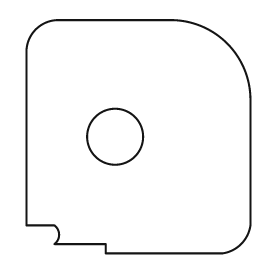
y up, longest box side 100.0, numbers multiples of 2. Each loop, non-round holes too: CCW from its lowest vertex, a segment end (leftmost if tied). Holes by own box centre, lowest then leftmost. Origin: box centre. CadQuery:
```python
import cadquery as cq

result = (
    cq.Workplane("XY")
    .moveTo(-14.0, -50.0)
    .lineTo(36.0, -50.0)
    .threePointArc((44.0, -46.0), (48.0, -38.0))
    .lineTo(48.0, 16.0)
    .threePointArc((38.0, 40.0), (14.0, 50.0))
    .lineTo(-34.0, 50.0)
    .threePointArc((-44.0, 46.0), (-48.0, 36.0))
    .lineTo(-48.0, -38.0)
    .lineTo(-36.0, -38.0)
    .threePointArc((-34.0, -42.0), (-36.0, -46.0))
    .lineTo(-14.0, -46.0)
    .close()
    .moveTo(-10.0, 0.0)
    .circle(12.0)
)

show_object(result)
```